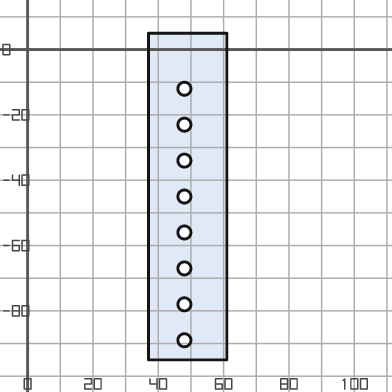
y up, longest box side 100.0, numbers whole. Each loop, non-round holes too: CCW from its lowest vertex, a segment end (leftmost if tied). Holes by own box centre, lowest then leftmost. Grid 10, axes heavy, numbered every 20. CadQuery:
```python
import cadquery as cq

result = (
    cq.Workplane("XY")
    .moveTo(37.0, -95.0)
    .lineTo(61.0, -95.0)
    .lineTo(61.0, 5.0)
    .lineTo(37.0, 5.0)
    .close()
    .moveTo(48.0, -89.0)
    .circle(2.0)
    .moveTo(48.0, -78.0)
    .circle(2.0)
    .moveTo(48.0, -67.0)
    .circle(2.0)
    .moveTo(48.0, -56.0)
    .circle(2.0)
    .moveTo(48.0, -45.0)
    .circle(2.0)
    .moveTo(48.0, -34.0)
    .circle(2.0)
    .moveTo(48.0, -23.0)
    .circle(2.0)
    .moveTo(48.0, -12.0)
    .circle(2.0)
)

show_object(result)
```